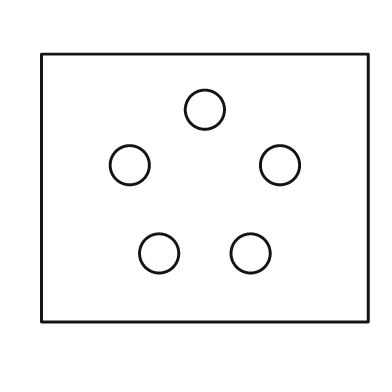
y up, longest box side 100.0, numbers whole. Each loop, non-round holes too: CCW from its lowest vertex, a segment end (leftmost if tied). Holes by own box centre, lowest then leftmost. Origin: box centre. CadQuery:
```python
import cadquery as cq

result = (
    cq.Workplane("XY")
    .moveTo(-50.0, -41.0)
    .lineTo(50.0, -41.0)
    .lineTo(50.0, 41.0)
    .lineTo(-50.0, 41.0)
    .close()
    .moveTo(-14.0, -20.0)
    .circle(6.0)
    .moveTo(14.0, -20.0)
    .circle(6.0)
    .moveTo(-23.0, 7.0)
    .circle(6.0)
    .moveTo(23.0, 7.0)
    .circle(6.0)
    .moveTo(0.0, 24.0)
    .circle(6.0)
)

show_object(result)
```